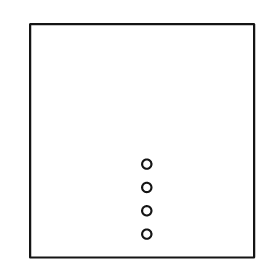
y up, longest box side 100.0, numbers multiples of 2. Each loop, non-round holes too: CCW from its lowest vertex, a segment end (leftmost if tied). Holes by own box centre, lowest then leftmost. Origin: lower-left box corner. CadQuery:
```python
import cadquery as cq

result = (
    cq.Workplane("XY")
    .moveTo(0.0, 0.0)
    .lineTo(96.0, 0.0)
    .lineTo(96.0, 100.0)
    .lineTo(0.0, 100.0)
    .close()
    .moveTo(50.0, 10.0)
    .circle(2.0)
    .moveTo(50.0, 20.0)
    .circle(2.0)
    .moveTo(50.0, 30.0)
    .circle(2.0)
    .moveTo(50.0, 40.0)
    .circle(2.0)
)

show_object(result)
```